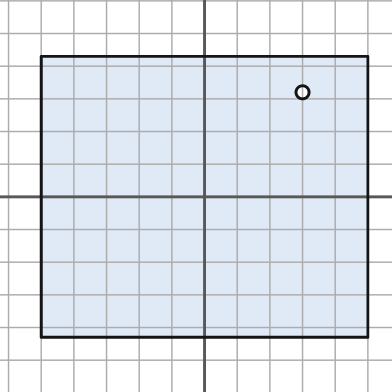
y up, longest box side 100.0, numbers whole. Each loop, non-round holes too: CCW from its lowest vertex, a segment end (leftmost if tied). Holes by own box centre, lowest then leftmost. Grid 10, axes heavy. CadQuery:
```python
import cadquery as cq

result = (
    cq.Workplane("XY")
    .moveTo(-50.0, -43.0)
    .lineTo(50.0, -43.0)
    .lineTo(50.0, 43.0)
    .lineTo(-50.0, 43.0)
    .close()
    .moveTo(30.0, 32.0)
    .circle(2.0)
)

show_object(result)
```